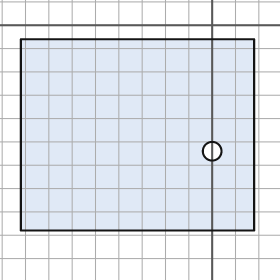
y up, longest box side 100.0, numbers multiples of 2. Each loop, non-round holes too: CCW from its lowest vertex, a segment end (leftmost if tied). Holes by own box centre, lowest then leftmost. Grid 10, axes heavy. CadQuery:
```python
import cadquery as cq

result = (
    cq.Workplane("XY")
    .moveTo(-82.0, -88.0)
    .lineTo(18.0, -88.0)
    .lineTo(18.0, -6.0)
    .lineTo(-82.0, -6.0)
    .close()
    .moveTo(0.0, -54.0)
    .circle(4.0)
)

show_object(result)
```